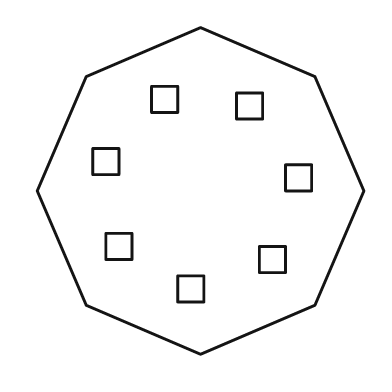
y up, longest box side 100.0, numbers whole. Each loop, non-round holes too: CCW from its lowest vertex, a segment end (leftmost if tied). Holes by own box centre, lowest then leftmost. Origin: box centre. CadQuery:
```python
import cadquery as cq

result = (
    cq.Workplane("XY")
    .moveTo(0.0, -50.0)
    .lineTo(35.0, -35.0)
    .lineTo(50.0, 0.0)
    .lineTo(35.0, 35.0)
    .lineTo(0.0, 50.0)
    .lineTo(-35.0, 35.0)
    .lineTo(-50.0, 0.0)
    .lineTo(-35.0, -35.0)
    .close()
    .moveTo(-7.0, -34.0)
    .lineTo(1.0, -34.0)
    .lineTo(1.0, -26.0)
    .lineTo(-7.0, -26.0)
    .close()
    .moveTo(18.0, -25.0)
    .lineTo(26.0, -25.0)
    .lineTo(26.0, -17.0)
    .lineTo(18.0, -17.0)
    .close()
    .moveTo(-29.0, -21.0)
    .lineTo(-21.0, -21.0)
    .lineTo(-21.0, -13.0)
    .lineTo(-29.0, -13.0)
    .close()
    .moveTo(26.0, 0.0)
    .lineTo(34.0, 0.0)
    .lineTo(34.0, 8.0)
    .lineTo(26.0, 8.0)
    .close()
    .moveTo(-33.0, 5.0)
    .lineTo(-25.0, 5.0)
    .lineTo(-25.0, 13.0)
    .lineTo(-33.0, 13.0)
    .close()
    .moveTo(11.0, 22.0)
    .lineTo(19.0, 22.0)
    .lineTo(19.0, 30.0)
    .lineTo(11.0, 30.0)
    .close()
    .moveTo(-15.0, 24.0)
    .lineTo(-7.0, 24.0)
    .lineTo(-7.0, 32.0)
    .lineTo(-15.0, 32.0)
    .close()
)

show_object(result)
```